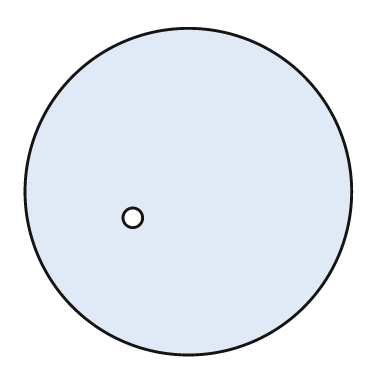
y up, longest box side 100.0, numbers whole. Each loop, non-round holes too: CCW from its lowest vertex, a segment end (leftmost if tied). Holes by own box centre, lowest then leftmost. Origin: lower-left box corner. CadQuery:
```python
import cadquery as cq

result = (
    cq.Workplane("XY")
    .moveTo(50.0, 50.0)
    .circle(50.0)
    .moveTo(33.0, 42.0)
    .circle(3.0)
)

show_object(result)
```